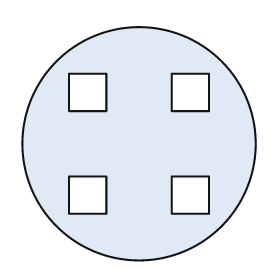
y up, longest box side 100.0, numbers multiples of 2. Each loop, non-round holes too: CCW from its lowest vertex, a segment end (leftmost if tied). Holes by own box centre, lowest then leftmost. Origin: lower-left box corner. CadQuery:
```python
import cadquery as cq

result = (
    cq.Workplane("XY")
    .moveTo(50.0, 50.0)
    .circle(50.0)
    .moveTo(20.0, 20.0)
    .lineTo(36.0, 20.0)
    .lineTo(36.0, 36.0)
    .lineTo(20.0, 36.0)
    .close()
    .moveTo(64.0, 20.0)
    .lineTo(80.0, 20.0)
    .lineTo(80.0, 36.0)
    .lineTo(64.0, 36.0)
    .close()
    .moveTo(20.0, 64.0)
    .lineTo(36.0, 64.0)
    .lineTo(36.0, 80.0)
    .lineTo(20.0, 80.0)
    .close()
    .moveTo(64.0, 64.0)
    .lineTo(80.0, 64.0)
    .lineTo(80.0, 80.0)
    .lineTo(64.0, 80.0)
    .close()
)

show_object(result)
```